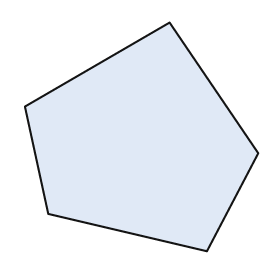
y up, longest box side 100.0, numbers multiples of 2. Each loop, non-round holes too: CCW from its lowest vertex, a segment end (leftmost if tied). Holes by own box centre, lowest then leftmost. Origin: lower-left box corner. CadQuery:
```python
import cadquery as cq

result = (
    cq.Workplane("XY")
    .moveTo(78.0, 0.0)
    .lineTo(100.0, 42.0)
    .lineTo(62.0, 98.0)
    .lineTo(0.0, 62.0)
    .lineTo(10.0, 16.0)
    .close()
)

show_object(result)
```